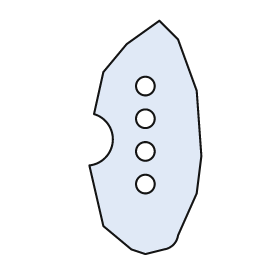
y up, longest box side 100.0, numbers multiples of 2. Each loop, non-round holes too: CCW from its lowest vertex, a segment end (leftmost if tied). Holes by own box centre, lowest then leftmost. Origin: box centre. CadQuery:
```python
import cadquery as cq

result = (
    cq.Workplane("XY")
    .moveTo(0.0, -50.0)
    .lineTo(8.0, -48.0)
    .threePointArc((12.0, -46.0), (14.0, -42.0))
    .lineTo(22.0, -24.0)
    .lineTo(24.0, -8.0)
    .lineTo(22.0, 20.0)
    .lineTo(14.0, 42.0)
    .lineTo(6.0, 50.0)
    .lineTo(-8.0, 40.0)
    .lineTo(-18.0, 28.0)
    .lineTo(-22.0, 10.0)
    .threePointArc((-14.0, -2.0), (-24.0, -12.0))
    .lineTo(-18.0, -38.0)
    .lineTo(-6.0, -48.0)
    .close()
    .moveTo(0.0, -20.0)
    .circle(4.0)
    .moveTo(0.0, -6.0)
    .circle(4.0)
    .moveTo(0.0, 8.0)
    .circle(4.0)
    .moveTo(0.0, 22.0)
    .circle(4.0)
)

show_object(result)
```